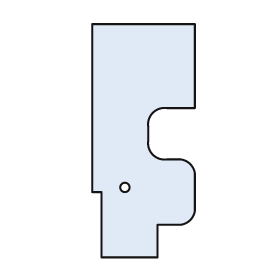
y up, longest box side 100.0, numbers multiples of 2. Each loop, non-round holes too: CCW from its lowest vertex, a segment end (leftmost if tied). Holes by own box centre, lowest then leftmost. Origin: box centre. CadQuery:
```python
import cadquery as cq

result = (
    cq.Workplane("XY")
    .moveTo(-18.0, -50.0)
    .lineTo(6.0, -50.0)
    .lineTo(6.0, -36.0)
    .lineTo(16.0, -36.0)
    .threePointArc((20.0, -34.0), (22.0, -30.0))
    .lineTo(22.0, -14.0)
    .threePointArc((20.0, -10.0), (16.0, -8.0))
    .lineTo(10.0, -8.0)
    .threePointArc((4.0, -6.0), (2.0, 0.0))
    .lineTo(2.0, 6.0)
    .threePointArc((4.0, 12.0), (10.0, 14.0))
    .lineTo(22.0, 14.0)
    .lineTo(22.0, 50.0)
    .lineTo(-22.0, 50.0)
    .lineTo(-22.0, -22.0)
    .lineTo(-18.0, -22.0)
    .close()
    .moveTo(-8.0, -20.0)
    .circle(2.0)
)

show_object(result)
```